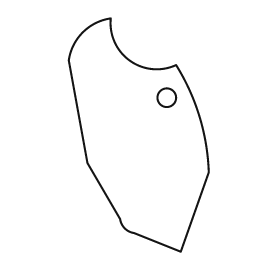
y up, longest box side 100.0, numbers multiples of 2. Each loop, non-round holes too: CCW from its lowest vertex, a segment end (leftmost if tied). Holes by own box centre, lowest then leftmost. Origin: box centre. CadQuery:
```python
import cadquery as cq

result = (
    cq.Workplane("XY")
    .moveTo(18.0, -50.0)
    .lineTo(30.0, -16.0)
    .threePointArc((26.0, 8.0), (16.0, 30.0))
    .threePointArc((-4.0, 32.0), (-12.0, 50.0))
    .threePointArc((-24.0, 44.0), (-30.0, 32.0))
    .lineTo(-22.0, -12.0)
    .lineTo(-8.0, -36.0)
    .threePointArc((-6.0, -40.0), (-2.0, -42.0))
    .close()
    .moveTo(12.0, 16.0)
    .circle(4.0)
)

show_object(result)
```